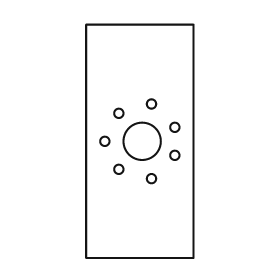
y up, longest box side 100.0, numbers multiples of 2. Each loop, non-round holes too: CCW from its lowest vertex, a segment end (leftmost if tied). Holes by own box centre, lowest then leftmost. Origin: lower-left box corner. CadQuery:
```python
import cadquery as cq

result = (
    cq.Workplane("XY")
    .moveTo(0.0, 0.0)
    .lineTo(46.0, 0.0)
    .lineTo(46.0, 100.0)
    .lineTo(0.0, 100.0)
    .close()
    .moveTo(28.0, 34.0)
    .circle(2.0)
    .moveTo(14.0, 38.0)
    .circle(2.0)
    .moveTo(38.0, 44.0)
    .circle(2.0)
    .moveTo(8.0, 50.0)
    .circle(2.0)
    .moveTo(24.0, 50.0)
    .circle(8.0)
    .moveTo(38.0, 56.0)
    .circle(2.0)
    .moveTo(14.0, 62.0)
    .circle(2.0)
    .moveTo(28.0, 66.0)
    .circle(2.0)
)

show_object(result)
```